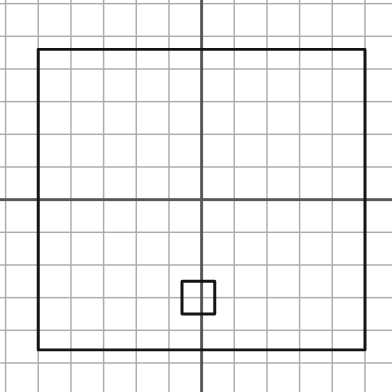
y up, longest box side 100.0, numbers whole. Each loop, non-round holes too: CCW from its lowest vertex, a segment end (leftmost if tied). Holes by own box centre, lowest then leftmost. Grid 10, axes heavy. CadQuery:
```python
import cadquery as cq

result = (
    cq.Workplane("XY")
    .moveTo(-50.0, -46.0)
    .lineTo(50.0, -46.0)
    .lineTo(50.0, 46.0)
    .lineTo(-50.0, 46.0)
    .close()
    .moveTo(-6.0, -35.0)
    .lineTo(4.0, -35.0)
    .lineTo(4.0, -25.0)
    .lineTo(-6.0, -25.0)
    .close()
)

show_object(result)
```